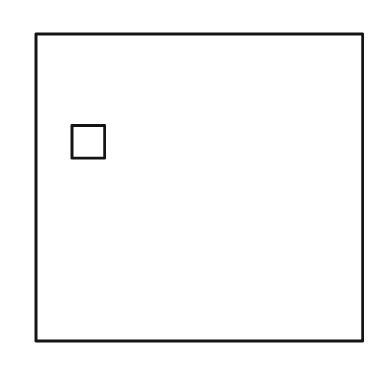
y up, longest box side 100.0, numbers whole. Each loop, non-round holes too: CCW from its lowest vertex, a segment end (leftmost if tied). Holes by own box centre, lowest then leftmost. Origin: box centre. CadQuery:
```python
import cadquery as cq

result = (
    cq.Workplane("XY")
    .moveTo(-50.0, -47.0)
    .lineTo(50.0, -47.0)
    .lineTo(50.0, 47.0)
    .lineTo(-50.0, 47.0)
    .close()
    .moveTo(-39.0, 9.0)
    .lineTo(-29.0, 9.0)
    .lineTo(-29.0, 19.0)
    .lineTo(-39.0, 19.0)
    .close()
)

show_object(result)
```